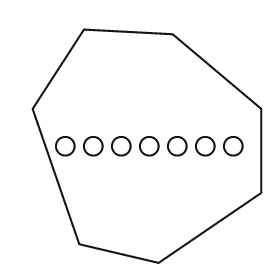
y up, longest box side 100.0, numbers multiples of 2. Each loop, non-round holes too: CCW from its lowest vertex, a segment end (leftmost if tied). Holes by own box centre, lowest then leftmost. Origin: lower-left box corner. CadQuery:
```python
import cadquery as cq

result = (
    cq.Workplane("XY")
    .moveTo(54.0, 0.0)
    .lineTo(98.0, 30.0)
    .lineTo(98.0, 66.0)
    .lineTo(60.0, 98.0)
    .lineTo(22.0, 100.0)
    .lineTo(0.0, 66.0)
    .lineTo(20.0, 8.0)
    .close()
    .moveTo(14.0, 50.0)
    .circle(4.0)
    .moveTo(26.0, 50.0)
    .circle(4.0)
    .moveTo(38.0, 50.0)
    .circle(4.0)
    .moveTo(50.0, 50.0)
    .circle(4.0)
    .moveTo(62.0, 50.0)
    .circle(4.0)
    .moveTo(74.0, 50.0)
    .circle(4.0)
    .moveTo(86.0, 50.0)
    .circle(4.0)
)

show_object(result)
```